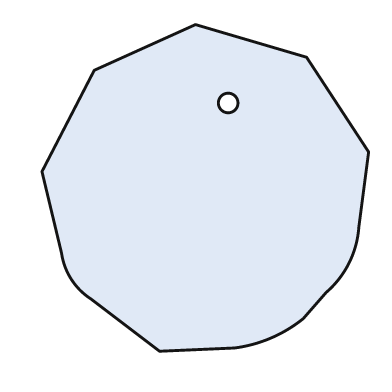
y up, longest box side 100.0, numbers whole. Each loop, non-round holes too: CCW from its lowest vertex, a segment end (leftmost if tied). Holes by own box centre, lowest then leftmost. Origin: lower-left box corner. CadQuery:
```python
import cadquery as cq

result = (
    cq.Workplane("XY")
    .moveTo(36.0, 0.0)
    .lineTo(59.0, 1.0)
    .threePointArc((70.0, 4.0), (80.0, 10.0))
    .lineTo(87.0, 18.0)
    .threePointArc((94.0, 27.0), (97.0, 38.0))
    .lineTo(100.0, 61.0)
    .lineTo(81.0, 90.0)
    .lineTo(47.0, 100.0)
    .lineTo(16.0, 86.0)
    .lineTo(0.0, 55.0)
    .lineTo(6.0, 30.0)
    .threePointArc((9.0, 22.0), (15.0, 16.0))
    .close()
    .moveTo(57.0, 76.0)
    .circle(3.0)
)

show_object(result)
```